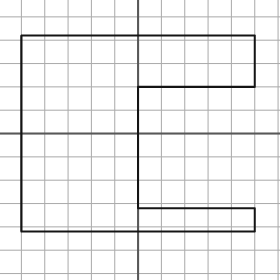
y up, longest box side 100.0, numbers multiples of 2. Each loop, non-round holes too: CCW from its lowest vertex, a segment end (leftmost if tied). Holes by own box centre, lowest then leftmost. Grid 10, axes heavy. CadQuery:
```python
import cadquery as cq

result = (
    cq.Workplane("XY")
    .moveTo(-50.0, -42.0)
    .lineTo(50.0, -42.0)
    .lineTo(50.0, -32.0)
    .lineTo(0.0, -32.0)
    .lineTo(0.0, 20.0)
    .lineTo(50.0, 20.0)
    .lineTo(50.0, 42.0)
    .lineTo(-50.0, 42.0)
    .close()
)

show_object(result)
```